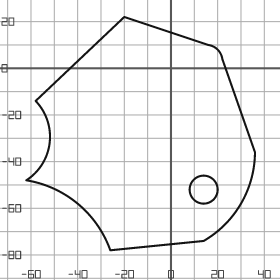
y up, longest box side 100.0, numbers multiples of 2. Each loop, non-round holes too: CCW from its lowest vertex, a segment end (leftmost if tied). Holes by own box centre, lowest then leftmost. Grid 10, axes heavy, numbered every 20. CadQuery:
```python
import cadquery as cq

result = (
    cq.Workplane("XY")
    .moveTo(-26.0, -78.0)
    .lineTo(14.0, -74.0)
    .threePointArc((30.0, -58.0), (36.0, -36.0))
    .lineTo(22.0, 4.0)
    .threePointArc((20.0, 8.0), (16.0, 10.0))
    .lineTo(-20.0, 22.0)
    .lineTo(-58.0, -14.0)
    .threePointArc((-52.0, -32.0), (-62.0, -48.0))
    .threePointArc((-40.0, -58.0), (-26.0, -78.0))
    .close()
    .moveTo(14.0, -52.0)
    .circle(6.0)
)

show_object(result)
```